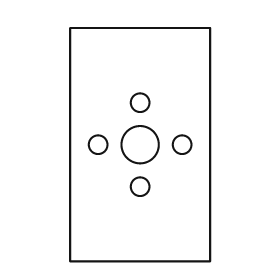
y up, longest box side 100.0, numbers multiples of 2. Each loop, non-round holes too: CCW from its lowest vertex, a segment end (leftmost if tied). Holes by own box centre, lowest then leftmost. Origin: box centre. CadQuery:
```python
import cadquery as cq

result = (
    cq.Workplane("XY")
    .moveTo(-30.0, -50.0)
    .lineTo(30.0, -50.0)
    .lineTo(30.0, 50.0)
    .lineTo(-30.0, 50.0)
    .close()
    .moveTo(0.0, -18.0)
    .circle(4.0)
    .moveTo(-18.0, 0.0)
    .circle(4.0)
    .moveTo(0.0, 0.0)
    .circle(8.0)
    .moveTo(18.0, 0.0)
    .circle(4.0)
    .moveTo(0.0, 18.0)
    .circle(4.0)
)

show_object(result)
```